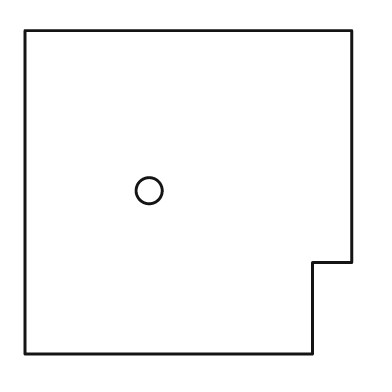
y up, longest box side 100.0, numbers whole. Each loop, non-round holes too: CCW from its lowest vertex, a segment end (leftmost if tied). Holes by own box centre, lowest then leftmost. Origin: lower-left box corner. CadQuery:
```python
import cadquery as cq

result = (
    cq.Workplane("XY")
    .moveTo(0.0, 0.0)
    .lineTo(88.0, 0.0)
    .lineTo(88.0, 28.0)
    .lineTo(100.0, 28.0)
    .lineTo(100.0, 99.0)
    .lineTo(0.0, 99.0)
    .close()
    .moveTo(38.0, 50.0)
    .circle(4.0)
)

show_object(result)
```